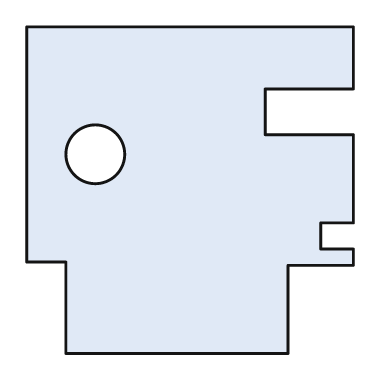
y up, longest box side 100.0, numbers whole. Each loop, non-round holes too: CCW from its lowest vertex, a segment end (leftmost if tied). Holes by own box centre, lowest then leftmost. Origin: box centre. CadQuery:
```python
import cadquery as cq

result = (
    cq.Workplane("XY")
    .moveTo(-38.0, -50.0)
    .lineTo(30.0, -50.0)
    .lineTo(30.0, -23.0)
    .lineTo(50.0, -23.0)
    .lineTo(50.0, -18.0)
    .lineTo(40.0, -18.0)
    .lineTo(40.0, -10.0)
    .lineTo(50.0, -10.0)
    .lineTo(50.0, 17.0)
    .lineTo(23.0, 17.0)
    .lineTo(23.0, 31.0)
    .lineTo(50.0, 31.0)
    .lineTo(50.0, 50.0)
    .lineTo(-50.0, 50.0)
    .lineTo(-50.0, -22.0)
    .lineTo(-38.0, -22.0)
    .close()
    .moveTo(-29.0, 11.0)
    .circle(9.0)
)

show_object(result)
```